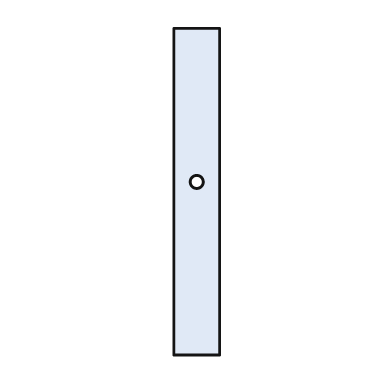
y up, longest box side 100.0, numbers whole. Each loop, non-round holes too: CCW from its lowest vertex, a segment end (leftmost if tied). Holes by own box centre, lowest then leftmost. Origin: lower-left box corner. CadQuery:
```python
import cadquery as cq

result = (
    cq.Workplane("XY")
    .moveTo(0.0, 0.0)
    .lineTo(14.0, 0.0)
    .lineTo(14.0, 100.0)
    .lineTo(0.0, 100.0)
    .close()
    .moveTo(7.0, 53.0)
    .circle(2.0)
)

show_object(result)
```